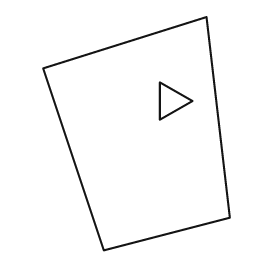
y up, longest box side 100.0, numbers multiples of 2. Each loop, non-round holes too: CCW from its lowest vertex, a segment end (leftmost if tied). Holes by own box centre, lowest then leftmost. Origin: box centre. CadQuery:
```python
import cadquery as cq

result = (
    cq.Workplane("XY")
    .moveTo(-14.0, -50.0)
    .lineTo(40.0, -36.0)
    .lineTo(30.0, 50.0)
    .lineTo(-40.0, 28.0)
    .close()
    .moveTo(10.0, 6.0)
    .lineTo(24.0, 14.0)
    .lineTo(10.0, 22.0)
    .close()
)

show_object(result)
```